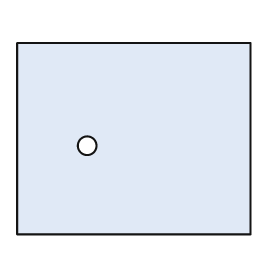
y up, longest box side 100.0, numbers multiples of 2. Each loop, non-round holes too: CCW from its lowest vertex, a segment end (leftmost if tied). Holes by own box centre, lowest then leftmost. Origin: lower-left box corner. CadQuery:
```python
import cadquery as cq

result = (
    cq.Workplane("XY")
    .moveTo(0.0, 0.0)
    .lineTo(100.0, 0.0)
    .lineTo(100.0, 82.0)
    .lineTo(0.0, 82.0)
    .close()
    .moveTo(30.0, 38.0)
    .circle(4.0)
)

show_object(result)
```